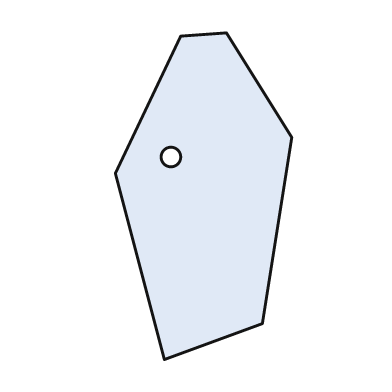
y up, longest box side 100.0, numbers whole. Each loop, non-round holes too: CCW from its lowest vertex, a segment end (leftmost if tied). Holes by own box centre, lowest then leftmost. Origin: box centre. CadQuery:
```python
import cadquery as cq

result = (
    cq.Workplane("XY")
    .moveTo(-12.0, -50.0)
    .lineTo(18.0, -39.0)
    .lineTo(27.0, 18.0)
    .lineTo(7.0, 50.0)
    .lineTo(-7.0, 49.0)
    .lineTo(-27.0, 7.0)
    .close()
    .moveTo(-10.0, 12.0)
    .circle(3.0)
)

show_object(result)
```